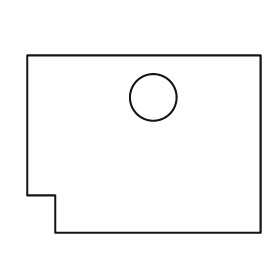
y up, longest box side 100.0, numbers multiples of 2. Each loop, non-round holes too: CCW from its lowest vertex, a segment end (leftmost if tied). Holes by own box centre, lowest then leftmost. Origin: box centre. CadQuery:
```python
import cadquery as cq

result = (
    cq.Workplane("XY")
    .moveTo(-38.0, -38.0)
    .lineTo(50.0, -38.0)
    .lineTo(50.0, 38.0)
    .lineTo(-50.0, 38.0)
    .lineTo(-50.0, -22.0)
    .lineTo(-38.0, -22.0)
    .close()
    .moveTo(4.0, 20.0)
    .circle(10.0)
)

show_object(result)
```